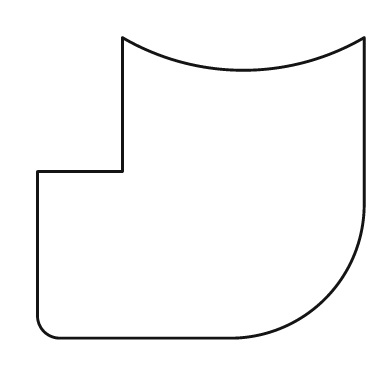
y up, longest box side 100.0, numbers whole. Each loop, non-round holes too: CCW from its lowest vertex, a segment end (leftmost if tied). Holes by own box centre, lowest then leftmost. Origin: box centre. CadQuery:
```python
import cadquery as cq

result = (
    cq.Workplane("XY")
    .moveTo(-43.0, -46.0)
    .lineTo(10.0, -46.0)
    .threePointArc((38.0, -34.0), (50.0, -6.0))
    .lineTo(50.0, 46.0)
    .threePointArc((13.0, 36.0), (-24.0, 46.0))
    .lineTo(-24.0, 5.0)
    .lineTo(-50.0, 5.0)
    .lineTo(-50.0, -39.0)
    .threePointArc((-48.0, -44.0), (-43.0, -46.0))
    .close()
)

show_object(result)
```